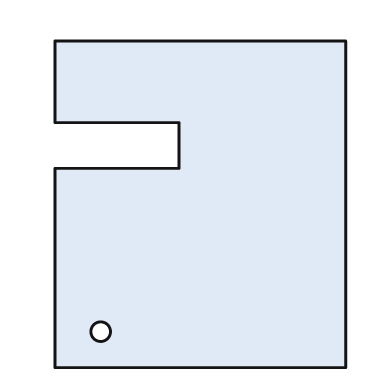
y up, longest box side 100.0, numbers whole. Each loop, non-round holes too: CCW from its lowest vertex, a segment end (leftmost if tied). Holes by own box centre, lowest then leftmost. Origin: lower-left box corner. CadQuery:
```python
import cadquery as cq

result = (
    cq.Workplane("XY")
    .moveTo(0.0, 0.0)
    .lineTo(89.0, 0.0)
    .lineTo(89.0, 100.0)
    .lineTo(0.0, 100.0)
    .lineTo(0.0, 75.0)
    .lineTo(38.0, 75.0)
    .lineTo(38.0, 61.0)
    .lineTo(0.0, 61.0)
    .close()
    .moveTo(14.0, 11.0)
    .circle(3.0)
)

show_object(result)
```